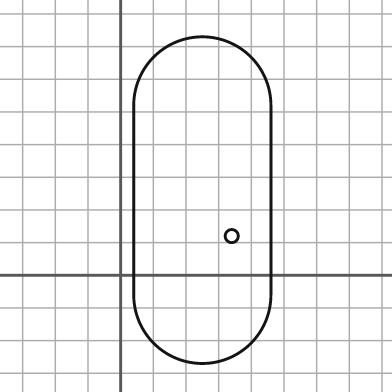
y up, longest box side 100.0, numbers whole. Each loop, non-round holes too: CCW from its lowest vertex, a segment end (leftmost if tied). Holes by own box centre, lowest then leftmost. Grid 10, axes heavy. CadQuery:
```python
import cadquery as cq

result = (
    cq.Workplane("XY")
    .moveTo(4.0, -6.0)
    .threePointArc((25.0, -27.0), (46.0, -6.0))
    .lineTo(46.0, 52.0)
    .threePointArc((25.0, 73.0), (4.0, 52.0))
    .close()
    .moveTo(34.0, 12.0)
    .circle(2.0)
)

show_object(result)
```